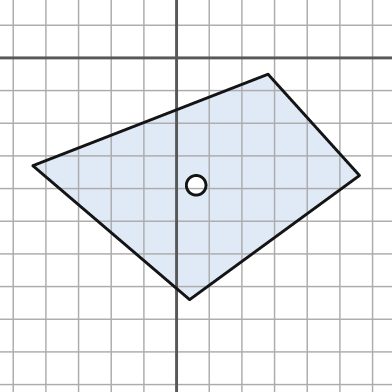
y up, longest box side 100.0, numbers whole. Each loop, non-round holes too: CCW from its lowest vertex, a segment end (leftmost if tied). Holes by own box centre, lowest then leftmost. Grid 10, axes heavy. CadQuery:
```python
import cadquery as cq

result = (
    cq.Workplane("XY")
    .moveTo(4.0, -74.0)
    .lineTo(56.0, -36.0)
    .lineTo(28.0, -5.0)
    .lineTo(-44.0, -33.0)
    .close()
    .moveTo(6.0, -39.0)
    .circle(3.0)
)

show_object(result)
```